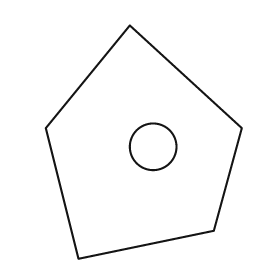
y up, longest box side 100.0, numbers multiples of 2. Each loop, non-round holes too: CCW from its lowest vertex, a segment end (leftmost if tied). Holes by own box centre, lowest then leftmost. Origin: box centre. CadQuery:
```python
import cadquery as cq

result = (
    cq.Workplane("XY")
    .moveTo(-28.0, -50.0)
    .lineTo(30.0, -38.0)
    .lineTo(42.0, 6.0)
    .lineTo(-6.0, 50.0)
    .lineTo(-42.0, 6.0)
    .close()
    .moveTo(4.0, -2.0)
    .circle(10.0)
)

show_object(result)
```